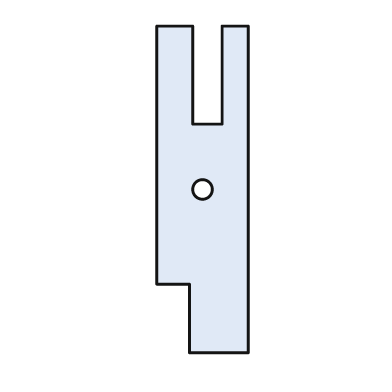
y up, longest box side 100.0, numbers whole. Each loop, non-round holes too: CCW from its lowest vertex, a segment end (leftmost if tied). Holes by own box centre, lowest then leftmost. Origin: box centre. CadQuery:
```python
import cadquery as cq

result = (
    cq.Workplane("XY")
    .moveTo(-4.0, -50.0)
    .lineTo(14.0, -50.0)
    .lineTo(14.0, 50.0)
    .lineTo(6.0, 50.0)
    .lineTo(6.0, 20.0)
    .lineTo(-3.0, 20.0)
    .lineTo(-3.0, 50.0)
    .lineTo(-14.0, 50.0)
    .lineTo(-14.0, -29.0)
    .lineTo(-4.0, -29.0)
    .close()
    .moveTo(0.0, 0.0)
    .circle(3.0)
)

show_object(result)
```